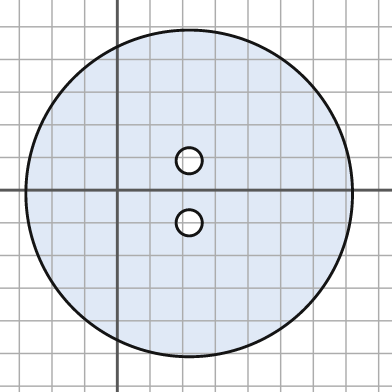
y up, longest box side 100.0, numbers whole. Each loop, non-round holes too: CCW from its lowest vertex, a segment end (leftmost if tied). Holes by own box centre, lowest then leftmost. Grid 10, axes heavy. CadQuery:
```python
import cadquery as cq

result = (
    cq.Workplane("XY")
    .moveTo(22.0, -1.0)
    .circle(50.0)
    .moveTo(22.0, -10.0)
    .circle(4.0)
    .moveTo(22.0, 9.0)
    .circle(4.0)
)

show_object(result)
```